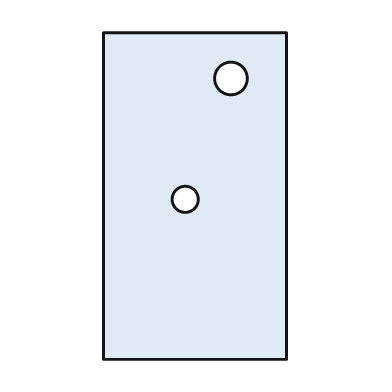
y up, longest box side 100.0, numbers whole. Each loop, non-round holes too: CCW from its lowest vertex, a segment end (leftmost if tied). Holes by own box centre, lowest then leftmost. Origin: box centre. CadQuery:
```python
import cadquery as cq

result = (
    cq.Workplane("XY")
    .moveTo(-28.0, -50.0)
    .lineTo(28.0, -50.0)
    .lineTo(28.0, 50.0)
    .lineTo(-28.0, 50.0)
    .close()
    .moveTo(-3.0, -1.0)
    .circle(4.0)
    .moveTo(11.0, 36.0)
    .circle(5.0)
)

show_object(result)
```